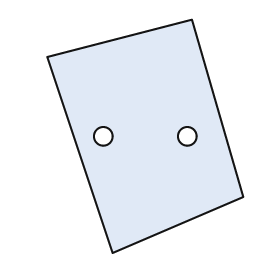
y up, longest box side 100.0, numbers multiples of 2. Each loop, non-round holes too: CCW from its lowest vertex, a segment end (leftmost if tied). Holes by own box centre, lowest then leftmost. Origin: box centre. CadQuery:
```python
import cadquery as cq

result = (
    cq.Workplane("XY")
    .moveTo(-14.0, -50.0)
    .lineTo(42.0, -26.0)
    .lineTo(20.0, 50.0)
    .lineTo(-42.0, 34.0)
    .close()
    .moveTo(-18.0, 0.0)
    .circle(4.0)
    .moveTo(18.0, 0.0)
    .circle(4.0)
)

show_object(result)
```